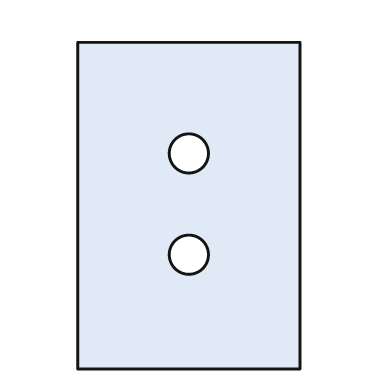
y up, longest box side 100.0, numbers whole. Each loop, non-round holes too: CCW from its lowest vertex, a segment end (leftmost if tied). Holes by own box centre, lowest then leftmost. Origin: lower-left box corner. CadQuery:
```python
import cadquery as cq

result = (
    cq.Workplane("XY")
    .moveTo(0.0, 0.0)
    .lineTo(68.0, 0.0)
    .lineTo(68.0, 100.0)
    .lineTo(0.0, 100.0)
    .close()
    .moveTo(34.0, 35.0)
    .circle(6.0)
    .moveTo(34.0, 66.0)
    .circle(6.0)
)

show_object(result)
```